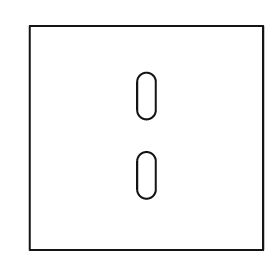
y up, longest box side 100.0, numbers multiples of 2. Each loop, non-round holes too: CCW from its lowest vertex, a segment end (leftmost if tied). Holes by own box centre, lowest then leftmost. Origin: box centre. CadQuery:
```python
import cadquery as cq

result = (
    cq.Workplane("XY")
    .moveTo(-50.0, -48.0)
    .lineTo(50.0, -48.0)
    .lineTo(50.0, 48.0)
    .lineTo(-50.0, 48.0)
    .close()
    .moveTo(-4.0, -22.0)
    .threePointArc((0.0, -26.0), (4.0, -22.0))
    .lineTo(4.0, -10.0)
    .threePointArc((0.0, -6.0), (-4.0, -10.0))
    .close()
    .moveTo(-4.0, 12.0)
    .threePointArc((0.0, 8.0), (4.0, 12.0))
    .lineTo(4.0, 24.0)
    .threePointArc((0.0, 28.0), (-4.0, 24.0))
    .close()
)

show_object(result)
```